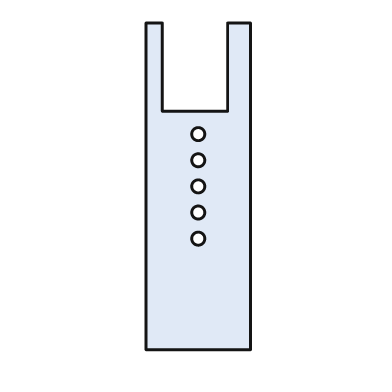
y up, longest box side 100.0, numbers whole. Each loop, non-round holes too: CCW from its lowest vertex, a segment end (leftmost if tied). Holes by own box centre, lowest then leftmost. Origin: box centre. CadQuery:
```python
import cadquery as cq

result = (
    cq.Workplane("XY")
    .moveTo(-16.0, -50.0)
    .lineTo(16.0, -50.0)
    .lineTo(16.0, 50.0)
    .lineTo(9.0, 50.0)
    .lineTo(9.0, 23.0)
    .lineTo(-11.0, 23.0)
    .lineTo(-11.0, 50.0)
    .lineTo(-16.0, 50.0)
    .close()
    .moveTo(0.0, -16.0)
    .circle(2.0)
    .moveTo(0.0, -8.0)
    .circle(2.0)
    .moveTo(0.0, 0.0)
    .circle(2.0)
    .moveTo(0.0, 8.0)
    .circle(2.0)
    .moveTo(0.0, 16.0)
    .circle(2.0)
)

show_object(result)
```